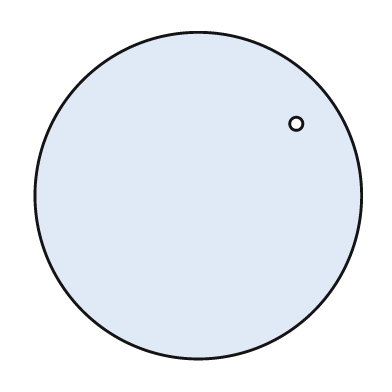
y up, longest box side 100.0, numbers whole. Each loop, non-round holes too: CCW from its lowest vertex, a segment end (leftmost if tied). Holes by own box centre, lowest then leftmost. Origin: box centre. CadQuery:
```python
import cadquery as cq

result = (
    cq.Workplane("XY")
    .moveTo(0.0, 0.0)
    .circle(50.0)
    .moveTo(30.0, 22.0)
    .circle(2.0)
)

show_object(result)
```